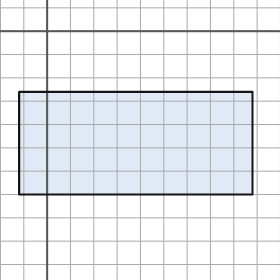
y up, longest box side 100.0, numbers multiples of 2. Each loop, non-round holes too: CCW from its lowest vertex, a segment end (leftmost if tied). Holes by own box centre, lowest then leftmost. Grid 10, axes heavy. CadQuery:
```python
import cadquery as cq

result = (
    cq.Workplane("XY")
    .moveTo(-12.0, -70.0)
    .lineTo(88.0, -70.0)
    .lineTo(88.0, -26.0)
    .lineTo(-12.0, -26.0)
    .close()
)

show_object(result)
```